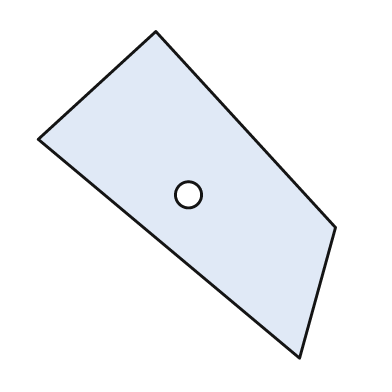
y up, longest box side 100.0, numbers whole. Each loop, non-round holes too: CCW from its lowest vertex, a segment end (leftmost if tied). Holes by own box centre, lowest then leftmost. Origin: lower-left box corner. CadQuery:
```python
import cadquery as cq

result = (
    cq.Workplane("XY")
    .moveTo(80.0, 0.0)
    .lineTo(91.0, 40.0)
    .lineTo(36.0, 100.0)
    .lineTo(0.0, 67.0)
    .close()
    .moveTo(46.0, 50.0)
    .circle(4.0)
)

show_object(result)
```